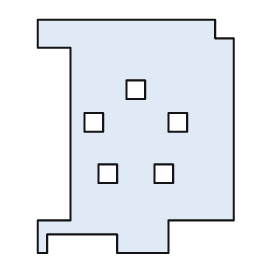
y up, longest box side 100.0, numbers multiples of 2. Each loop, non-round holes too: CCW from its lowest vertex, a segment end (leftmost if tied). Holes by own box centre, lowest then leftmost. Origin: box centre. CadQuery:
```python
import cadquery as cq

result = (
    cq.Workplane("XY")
    .moveTo(-42.0, -50.0)
    .lineTo(-38.0, -50.0)
    .lineTo(-38.0, -42.0)
    .lineTo(-8.0, -42.0)
    .lineTo(-8.0, -50.0)
    .lineTo(14.0, -50.0)
    .lineTo(14.0, -36.0)
    .lineTo(42.0, -36.0)
    .lineTo(42.0, 42.0)
    .lineTo(34.0, 42.0)
    .lineTo(34.0, 50.0)
    .lineTo(-42.0, 50.0)
    .lineTo(-42.0, 38.0)
    .lineTo(-28.0, 38.0)
    .lineTo(-28.0, -36.0)
    .lineTo(-42.0, -36.0)
    .close()
    .moveTo(-16.0, -20.0)
    .lineTo(-8.0, -20.0)
    .lineTo(-8.0, -12.0)
    .lineTo(-16.0, -12.0)
    .close()
    .moveTo(8.0, -20.0)
    .lineTo(16.0, -20.0)
    .lineTo(16.0, -12.0)
    .lineTo(8.0, -12.0)
    .close()
    .moveTo(-22.0, 2.0)
    .lineTo(-14.0, 2.0)
    .lineTo(-14.0, 10.0)
    .lineTo(-22.0, 10.0)
    .close()
    .moveTo(14.0, 2.0)
    .lineTo(22.0, 2.0)
    .lineTo(22.0, 10.0)
    .lineTo(14.0, 10.0)
    .close()
    .moveTo(-4.0, 16.0)
    .lineTo(4.0, 16.0)
    .lineTo(4.0, 24.0)
    .lineTo(-4.0, 24.0)
    .close()
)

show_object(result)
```